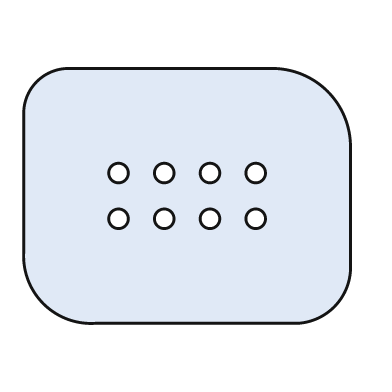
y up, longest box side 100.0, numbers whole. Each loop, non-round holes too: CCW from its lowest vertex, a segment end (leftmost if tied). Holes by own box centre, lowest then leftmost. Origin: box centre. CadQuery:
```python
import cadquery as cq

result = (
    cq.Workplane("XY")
    .moveTo(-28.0, -39.0)
    .lineTo(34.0, -39.0)
    .threePointArc((45.0, -34.0), (50.0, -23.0))
    .lineTo(50.0, 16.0)
    .threePointArc((43.0, 32.0), (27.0, 39.0))
    .lineTo(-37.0, 39.0)
    .threePointArc((-46.0, 35.0), (-50.0, 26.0))
    .lineTo(-50.0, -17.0)
    .threePointArc((-44.0, -33.0), (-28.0, -39.0))
    .close()
    .moveTo(-21.0, -7.0)
    .circle(3.0)
    .moveTo(-7.0, -7.0)
    .circle(3.0)
    .moveTo(7.0, -7.0)
    .circle(3.0)
    .moveTo(21.0, -7.0)
    .circle(3.0)
    .moveTo(-21.0, 7.0)
    .circle(3.0)
    .moveTo(-7.0, 7.0)
    .circle(3.0)
    .moveTo(7.0, 7.0)
    .circle(3.0)
    .moveTo(21.0, 7.0)
    .circle(3.0)
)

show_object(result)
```